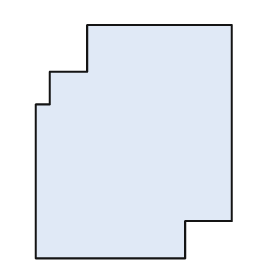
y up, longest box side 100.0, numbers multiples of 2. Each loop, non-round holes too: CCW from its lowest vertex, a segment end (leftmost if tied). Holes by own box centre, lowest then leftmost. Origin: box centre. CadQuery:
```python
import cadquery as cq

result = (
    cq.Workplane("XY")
    .moveTo(-42.0, -50.0)
    .lineTo(22.0, -50.0)
    .lineTo(22.0, -34.0)
    .lineTo(42.0, -34.0)
    .lineTo(42.0, 50.0)
    .lineTo(-20.0, 50.0)
    .lineTo(-20.0, 30.0)
    .lineTo(-36.0, 30.0)
    .lineTo(-36.0, 16.0)
    .lineTo(-42.0, 16.0)
    .close()
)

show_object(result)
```